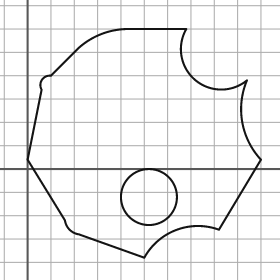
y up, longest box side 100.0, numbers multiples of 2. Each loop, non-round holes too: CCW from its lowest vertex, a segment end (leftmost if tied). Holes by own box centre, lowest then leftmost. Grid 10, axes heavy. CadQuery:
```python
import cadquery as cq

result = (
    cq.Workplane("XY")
    .moveTo(50.0, -38.0)
    .threePointArc((64.0, -26.0), (82.0, -26.0))
    .lineTo(100.0, 4.0)
    .threePointArc((92.0, 20.0), (94.0, 38.0))
    .threePointArc((72.0, 38.0), (68.0, 60.0))
    .lineTo(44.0, 60.0)
    .threePointArc((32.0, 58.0), (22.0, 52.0))
    .lineTo(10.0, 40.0)
    .threePointArc((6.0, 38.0), (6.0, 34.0))
    .lineTo(0.0, 4.0)
    .lineTo(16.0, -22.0)
    .threePointArc((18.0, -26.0), (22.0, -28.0))
    .close()
    .moveTo(52.0, -12.0)
    .circle(12.0)
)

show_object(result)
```